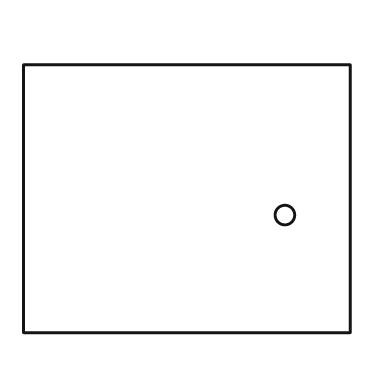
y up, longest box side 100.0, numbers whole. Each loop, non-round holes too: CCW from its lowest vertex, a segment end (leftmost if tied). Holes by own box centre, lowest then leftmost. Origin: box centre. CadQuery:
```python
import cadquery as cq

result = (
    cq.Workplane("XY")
    .moveTo(-50.0, -41.0)
    .lineTo(50.0, -41.0)
    .lineTo(50.0, 41.0)
    .lineTo(-50.0, 41.0)
    .close()
    .moveTo(30.0, -5.0)
    .circle(3.0)
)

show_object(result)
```